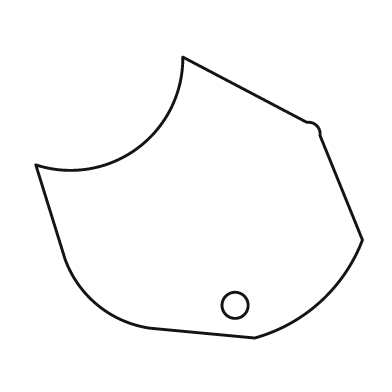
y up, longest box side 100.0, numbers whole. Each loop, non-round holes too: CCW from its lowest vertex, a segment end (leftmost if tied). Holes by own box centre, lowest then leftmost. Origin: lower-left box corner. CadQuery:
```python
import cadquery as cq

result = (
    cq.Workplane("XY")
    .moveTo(67.0, 0.0)
    .threePointArc((87.0, 11.0), (100.0, 30.0))
    .lineTo(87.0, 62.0)
    .threePointArc((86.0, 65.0), (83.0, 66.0))
    .lineTo(45.0, 86.0)
    .threePointArc((31.0, 58.0), (0.0, 53.0))
    .lineTo(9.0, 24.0)
    .threePointArc((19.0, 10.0), (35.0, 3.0))
    .close()
    .moveTo(61.0, 10.0)
    .circle(4.0)
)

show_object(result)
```